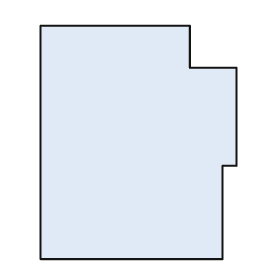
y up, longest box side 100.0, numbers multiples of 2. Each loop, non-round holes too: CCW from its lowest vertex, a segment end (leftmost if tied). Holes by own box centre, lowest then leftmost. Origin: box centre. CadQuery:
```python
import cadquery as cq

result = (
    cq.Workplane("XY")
    .moveTo(-42.0, -50.0)
    .lineTo(36.0, -50.0)
    .lineTo(36.0, -10.0)
    .lineTo(42.0, -10.0)
    .lineTo(42.0, 32.0)
    .lineTo(22.0, 32.0)
    .lineTo(22.0, 50.0)
    .lineTo(-42.0, 50.0)
    .close()
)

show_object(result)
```